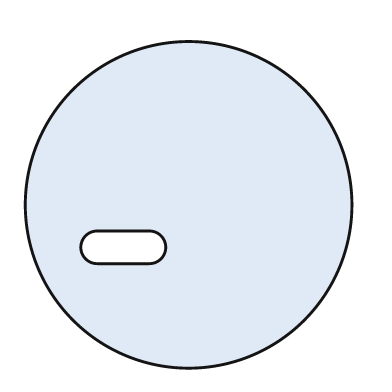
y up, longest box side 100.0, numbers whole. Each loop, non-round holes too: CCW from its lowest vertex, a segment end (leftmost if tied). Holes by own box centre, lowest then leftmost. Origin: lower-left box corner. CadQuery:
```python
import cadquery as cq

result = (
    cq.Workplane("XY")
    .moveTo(50.0, 50.0)
    .circle(50.0)
    .moveTo(22.0, 32.0)
    .lineTo(38.0, 32.0)
    .threePointArc((43.0, 37.0), (38.0, 42.0))
    .lineTo(22.0, 42.0)
    .threePointArc((17.0, 37.0), (22.0, 32.0))
    .close()
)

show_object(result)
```